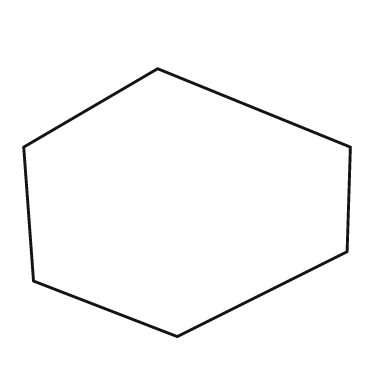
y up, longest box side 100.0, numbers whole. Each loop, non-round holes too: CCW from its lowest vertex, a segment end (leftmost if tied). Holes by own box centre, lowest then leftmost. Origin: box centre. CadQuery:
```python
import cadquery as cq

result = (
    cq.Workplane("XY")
    .moveTo(-3.0, -41.0)
    .lineTo(49.0, -15.0)
    .lineTo(50.0, 17.0)
    .lineTo(-9.0, 41.0)
    .lineTo(-50.0, 17.0)
    .lineTo(-47.0, -24.0)
    .close()
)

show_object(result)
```